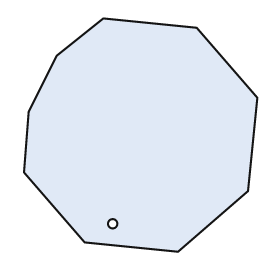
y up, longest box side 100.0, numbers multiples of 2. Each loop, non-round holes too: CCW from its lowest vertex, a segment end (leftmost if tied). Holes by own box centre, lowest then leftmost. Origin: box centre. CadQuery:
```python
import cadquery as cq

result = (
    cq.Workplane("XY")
    .moveTo(16.0, -50.0)
    .lineTo(46.0, -24.0)
    .lineTo(50.0, 16.0)
    .lineTo(24.0, 46.0)
    .lineTo(-16.0, 50.0)
    .lineTo(-36.0, 34.0)
    .lineTo(-48.0, 10.0)
    .lineTo(-50.0, -16.0)
    .lineTo(-24.0, -46.0)
    .close()
    .moveTo(-12.0, -38.0)
    .circle(2.0)
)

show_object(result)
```